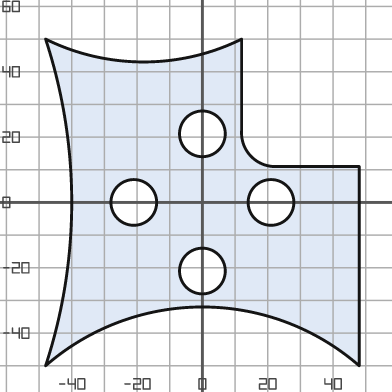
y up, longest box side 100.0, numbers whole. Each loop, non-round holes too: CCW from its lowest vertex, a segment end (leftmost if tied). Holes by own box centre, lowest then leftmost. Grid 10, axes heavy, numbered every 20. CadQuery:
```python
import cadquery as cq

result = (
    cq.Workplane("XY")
    .moveTo(-48.0, -50.0)
    .threePointArc((0.0, -32.0), (48.0, -50.0))
    .lineTo(48.0, 11.0)
    .lineTo(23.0, 11.0)
    .threePointArc((15.0, 14.0), (12.0, 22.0))
    .lineTo(12.0, 50.0)
    .threePointArc((-18.0, 43.0), (-48.0, 50.0))
    .threePointArc((-40.0, 0.0), (-48.0, -50.0))
    .close()
    .moveTo(0.0, -21.0)
    .circle(7.0)
    .moveTo(-21.0, 0.0)
    .circle(7.0)
    .moveTo(21.0, 0.0)
    .circle(7.0)
    .moveTo(0.0, 21.0)
    .circle(7.0)
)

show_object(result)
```